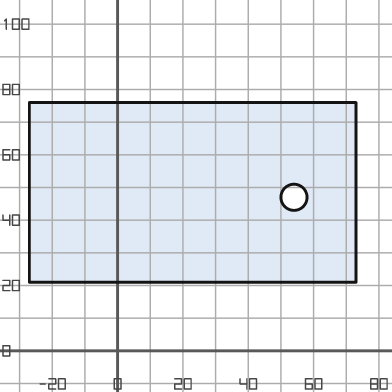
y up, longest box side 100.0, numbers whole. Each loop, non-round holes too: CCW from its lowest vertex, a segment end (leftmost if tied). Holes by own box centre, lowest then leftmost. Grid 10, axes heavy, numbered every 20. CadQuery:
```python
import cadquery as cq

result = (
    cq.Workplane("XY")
    .moveTo(-27.0, 21.0)
    .lineTo(73.0, 21.0)
    .lineTo(73.0, 76.0)
    .lineTo(-27.0, 76.0)
    .close()
    .moveTo(54.0, 47.0)
    .circle(4.0)
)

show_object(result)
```